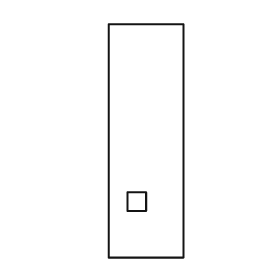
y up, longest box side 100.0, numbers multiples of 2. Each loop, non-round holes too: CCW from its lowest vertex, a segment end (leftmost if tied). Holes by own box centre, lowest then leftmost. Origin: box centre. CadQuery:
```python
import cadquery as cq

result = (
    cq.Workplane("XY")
    .moveTo(-16.0, -50.0)
    .lineTo(16.0, -50.0)
    .lineTo(16.0, 50.0)
    .lineTo(-16.0, 50.0)
    .close()
    .moveTo(-8.0, -30.0)
    .lineTo(0.0, -30.0)
    .lineTo(0.0, -22.0)
    .lineTo(-8.0, -22.0)
    .close()
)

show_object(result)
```